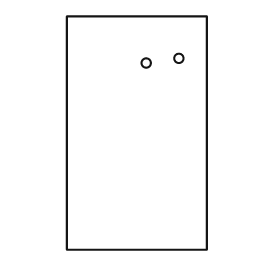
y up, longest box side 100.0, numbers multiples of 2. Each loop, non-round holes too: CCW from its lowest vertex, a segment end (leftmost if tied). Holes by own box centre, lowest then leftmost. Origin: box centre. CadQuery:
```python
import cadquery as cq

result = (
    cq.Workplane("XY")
    .moveTo(-30.0, -50.0)
    .lineTo(30.0, -50.0)
    .lineTo(30.0, 50.0)
    .lineTo(-30.0, 50.0)
    .close()
    .moveTo(4.0, 30.0)
    .circle(2.0)
    .moveTo(18.0, 32.0)
    .circle(2.0)
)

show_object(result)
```